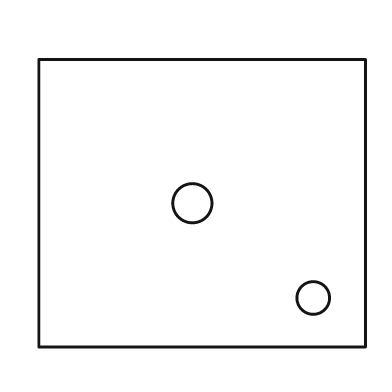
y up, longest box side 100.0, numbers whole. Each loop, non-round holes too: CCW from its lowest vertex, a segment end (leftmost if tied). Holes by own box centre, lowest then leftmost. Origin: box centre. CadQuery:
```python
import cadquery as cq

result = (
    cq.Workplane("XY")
    .moveTo(-50.0, -44.0)
    .lineTo(50.0, -44.0)
    .lineTo(50.0, 44.0)
    .lineTo(-50.0, 44.0)
    .close()
    .moveTo(34.0, -29.0)
    .circle(5.0)
    .moveTo(-3.0, 0.0)
    .circle(6.0)
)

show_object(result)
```